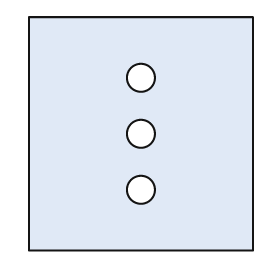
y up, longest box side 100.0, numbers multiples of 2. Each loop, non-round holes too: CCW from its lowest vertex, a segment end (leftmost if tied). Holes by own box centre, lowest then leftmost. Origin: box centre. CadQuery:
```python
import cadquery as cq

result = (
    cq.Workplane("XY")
    .moveTo(-48.0, -50.0)
    .lineTo(48.0, -50.0)
    .lineTo(48.0, 50.0)
    .lineTo(-48.0, 50.0)
    .close()
    .moveTo(0.0, -24.0)
    .circle(6.0)
    .moveTo(0.0, 0.0)
    .circle(6.0)
    .moveTo(0.0, 24.0)
    .circle(6.0)
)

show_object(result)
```